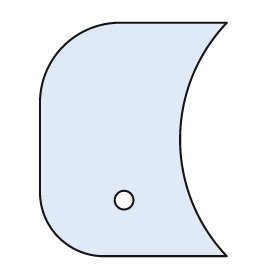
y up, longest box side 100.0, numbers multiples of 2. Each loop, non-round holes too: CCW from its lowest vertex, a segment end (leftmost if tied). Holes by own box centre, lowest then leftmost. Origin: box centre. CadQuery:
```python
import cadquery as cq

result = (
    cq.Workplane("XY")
    .moveTo(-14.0, -50.0)
    .lineTo(40.0, -50.0)
    .threePointArc((20.0, 0.0), (40.0, 50.0))
    .lineTo(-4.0, 50.0)
    .threePointArc((-30.0, 40.0), (-40.0, 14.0))
    .lineTo(-40.0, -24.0)
    .threePointArc((-32.0, -42.0), (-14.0, -50.0))
    .close()
    .moveTo(-4.0, -26.0)
    .circle(4.0)
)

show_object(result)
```